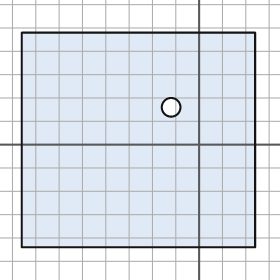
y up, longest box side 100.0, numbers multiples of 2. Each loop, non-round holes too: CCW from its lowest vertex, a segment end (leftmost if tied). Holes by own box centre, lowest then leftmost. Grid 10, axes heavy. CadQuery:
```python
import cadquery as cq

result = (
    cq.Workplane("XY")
    .moveTo(-76.0, -44.0)
    .lineTo(24.0, -44.0)
    .lineTo(24.0, 48.0)
    .lineTo(-76.0, 48.0)
    .close()
    .moveTo(-12.0, 16.0)
    .circle(4.0)
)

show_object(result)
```